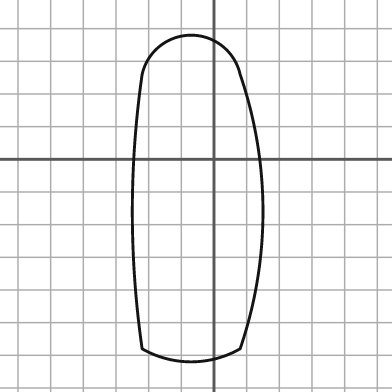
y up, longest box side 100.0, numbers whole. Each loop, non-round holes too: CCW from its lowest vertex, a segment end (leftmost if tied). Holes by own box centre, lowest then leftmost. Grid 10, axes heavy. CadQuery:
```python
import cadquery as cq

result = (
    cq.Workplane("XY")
    .moveTo(-22.0, -58.0)
    .threePointArc((-7.0, -62.0), (8.0, -58.0))
    .threePointArc((15.0, -16.0), (8.0, 26.0))
    .threePointArc((-7.0, 38.0), (-22.0, 26.0))
    .threePointArc((-25.0, -16.0), (-22.0, -58.0))
    .close()
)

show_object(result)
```